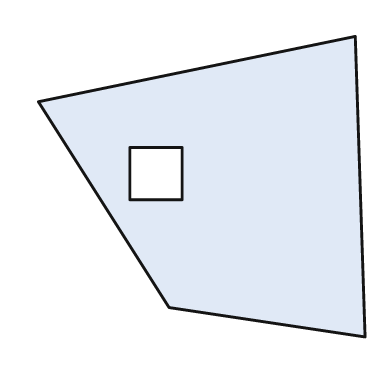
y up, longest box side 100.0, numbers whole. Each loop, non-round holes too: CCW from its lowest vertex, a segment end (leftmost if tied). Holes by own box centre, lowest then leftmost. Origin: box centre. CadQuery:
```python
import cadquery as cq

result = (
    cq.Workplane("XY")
    .moveTo(50.0, -46.0)
    .lineTo(47.0, 46.0)
    .lineTo(-50.0, 26.0)
    .lineTo(-10.0, -37.0)
    .close()
    .moveTo(-22.0, -4.0)
    .lineTo(-6.0, -4.0)
    .lineTo(-6.0, 12.0)
    .lineTo(-22.0, 12.0)
    .close()
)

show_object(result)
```